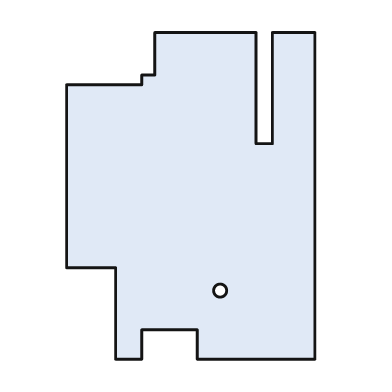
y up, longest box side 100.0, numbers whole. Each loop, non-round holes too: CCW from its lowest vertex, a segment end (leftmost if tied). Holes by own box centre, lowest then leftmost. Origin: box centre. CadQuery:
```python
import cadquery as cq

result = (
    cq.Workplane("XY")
    .moveTo(-23.0, -50.0)
    .lineTo(-15.0, -50.0)
    .lineTo(-15.0, -41.0)
    .lineTo(2.0, -41.0)
    .lineTo(2.0, -50.0)
    .lineTo(38.0, -50.0)
    .lineTo(38.0, 50.0)
    .lineTo(25.0, 50.0)
    .lineTo(25.0, 16.0)
    .lineTo(20.0, 16.0)
    .lineTo(20.0, 50.0)
    .lineTo(-11.0, 50.0)
    .lineTo(-11.0, 37.0)
    .lineTo(-15.0, 37.0)
    .lineTo(-15.0, 34.0)
    .lineTo(-38.0, 34.0)
    .lineTo(-38.0, -22.0)
    .lineTo(-23.0, -22.0)
    .close()
    .moveTo(9.0, -29.0)
    .circle(2.0)
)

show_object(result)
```